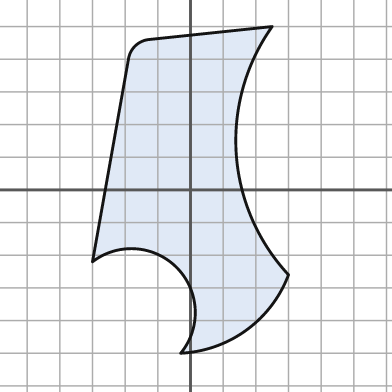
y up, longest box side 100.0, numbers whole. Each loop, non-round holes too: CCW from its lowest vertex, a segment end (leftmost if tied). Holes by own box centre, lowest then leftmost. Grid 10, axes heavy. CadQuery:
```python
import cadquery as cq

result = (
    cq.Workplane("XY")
    .moveTo(-3.0, -50.0)
    .threePointArc((17.0, -43.0), (30.0, -26.0))
    .threePointArc((14.0, 11.0), (25.0, 50.0))
    .lineTo(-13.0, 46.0)
    .threePointArc((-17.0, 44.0), (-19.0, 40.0))
    .lineTo(-30.0, -22.0)
    .threePointArc((-4.0, -24.0), (-3.0, -50.0))
    .close()
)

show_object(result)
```